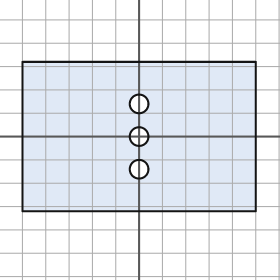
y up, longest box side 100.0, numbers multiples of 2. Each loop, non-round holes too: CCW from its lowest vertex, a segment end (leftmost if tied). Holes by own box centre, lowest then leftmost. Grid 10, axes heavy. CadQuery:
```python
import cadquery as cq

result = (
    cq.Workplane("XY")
    .moveTo(-50.0, -32.0)
    .lineTo(50.0, -32.0)
    .lineTo(50.0, 32.0)
    .lineTo(-50.0, 32.0)
    .close()
    .moveTo(0.0, -14.0)
    .circle(4.0)
    .moveTo(0.0, 0.0)
    .circle(4.0)
    .moveTo(0.0, 14.0)
    .circle(4.0)
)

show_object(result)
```